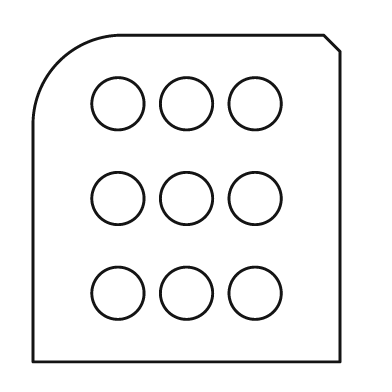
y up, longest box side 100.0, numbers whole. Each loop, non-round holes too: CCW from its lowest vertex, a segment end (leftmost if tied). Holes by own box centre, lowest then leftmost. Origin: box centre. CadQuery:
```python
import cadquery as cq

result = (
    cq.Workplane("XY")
    .moveTo(-47.0, -50.0)
    .lineTo(47.0, -50.0)
    .lineTo(47.0, 45.0)
    .lineTo(42.0, 50.0)
    .lineTo(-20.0, 50.0)
    .threePointArc((-39.0, 42.0), (-47.0, 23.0))
    .close()
    .moveTo(-21.0, -29.0)
    .circle(8.0)
    .moveTo(0.0, -29.0)
    .circle(8.0)
    .moveTo(21.0, -29.0)
    .circle(8.0)
    .moveTo(-21.0, 0.0)
    .circle(8.0)
    .moveTo(0.0, 0.0)
    .circle(8.0)
    .moveTo(21.0, 0.0)
    .circle(8.0)
    .moveTo(-21.0, 29.0)
    .circle(8.0)
    .moveTo(0.0, 29.0)
    .circle(8.0)
    .moveTo(21.0, 29.0)
    .circle(8.0)
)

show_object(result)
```